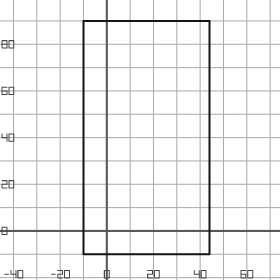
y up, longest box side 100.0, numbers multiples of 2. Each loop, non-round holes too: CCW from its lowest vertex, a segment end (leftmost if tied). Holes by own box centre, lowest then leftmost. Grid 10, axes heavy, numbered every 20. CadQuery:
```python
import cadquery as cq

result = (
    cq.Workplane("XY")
    .moveTo(-10.0, -10.0)
    .lineTo(44.0, -10.0)
    .lineTo(44.0, 90.0)
    .lineTo(-10.0, 90.0)
    .close()
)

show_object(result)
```